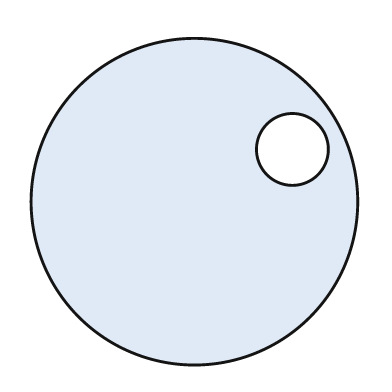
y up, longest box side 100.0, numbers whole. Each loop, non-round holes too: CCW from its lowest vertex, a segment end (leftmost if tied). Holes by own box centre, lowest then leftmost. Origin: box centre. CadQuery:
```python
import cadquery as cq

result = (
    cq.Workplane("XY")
    .moveTo(0.0, 0.0)
    .circle(50.0)
    .moveTo(30.0, 16.0)
    .circle(11.0)
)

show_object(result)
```